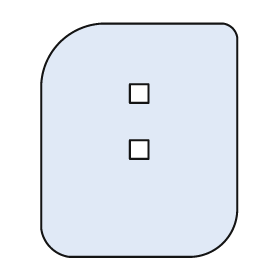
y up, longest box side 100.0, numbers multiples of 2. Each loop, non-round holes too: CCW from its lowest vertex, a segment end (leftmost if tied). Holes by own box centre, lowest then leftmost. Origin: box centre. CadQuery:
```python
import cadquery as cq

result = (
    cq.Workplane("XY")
    .moveTo(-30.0, -50.0)
    .lineTo(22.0, -50.0)
    .threePointArc((36.0, -44.0), (42.0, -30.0))
    .lineTo(42.0, 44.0)
    .threePointArc((40.0, 48.0), (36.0, 50.0))
    .lineTo(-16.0, 50.0)
    .threePointArc((-34.0, 42.0), (-42.0, 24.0))
    .lineTo(-42.0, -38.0)
    .threePointArc((-38.0, -46.0), (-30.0, -50.0))
    .close()
    .moveTo(-4.0, -8.0)
    .lineTo(4.0, -8.0)
    .lineTo(4.0, 0.0)
    .lineTo(-4.0, 0.0)
    .close()
    .moveTo(-4.0, 16.0)
    .lineTo(4.0, 16.0)
    .lineTo(4.0, 24.0)
    .lineTo(-4.0, 24.0)
    .close()
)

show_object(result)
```